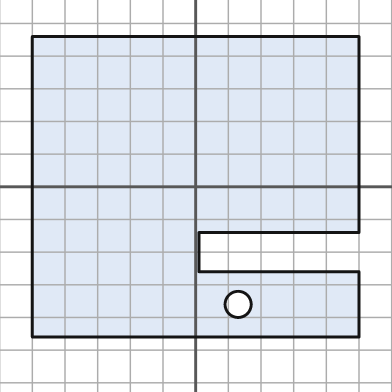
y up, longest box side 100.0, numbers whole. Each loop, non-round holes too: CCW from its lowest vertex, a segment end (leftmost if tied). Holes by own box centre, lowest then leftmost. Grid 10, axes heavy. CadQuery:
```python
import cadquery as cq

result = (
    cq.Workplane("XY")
    .moveTo(-50.0, -46.0)
    .lineTo(50.0, -46.0)
    .lineTo(50.0, -26.0)
    .lineTo(1.0, -26.0)
    .lineTo(1.0, -14.0)
    .lineTo(50.0, -14.0)
    .lineTo(50.0, 46.0)
    .lineTo(-50.0, 46.0)
    .close()
    .moveTo(13.0, -36.0)
    .circle(4.0)
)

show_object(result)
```